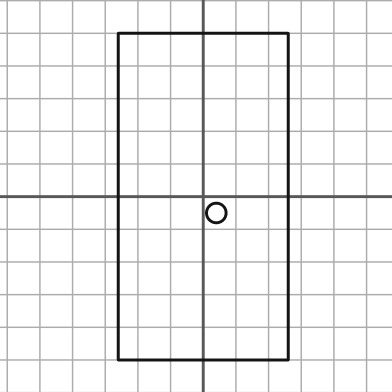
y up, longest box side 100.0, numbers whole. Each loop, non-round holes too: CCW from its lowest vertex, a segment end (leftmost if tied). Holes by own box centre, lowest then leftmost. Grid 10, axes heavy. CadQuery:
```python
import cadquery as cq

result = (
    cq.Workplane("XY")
    .moveTo(-26.0, -50.0)
    .lineTo(26.0, -50.0)
    .lineTo(26.0, 50.0)
    .lineTo(-26.0, 50.0)
    .close()
    .moveTo(4.0, -5.0)
    .circle(3.0)
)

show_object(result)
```